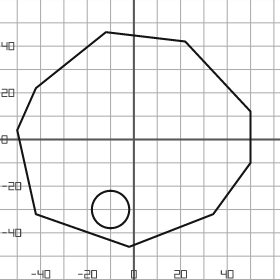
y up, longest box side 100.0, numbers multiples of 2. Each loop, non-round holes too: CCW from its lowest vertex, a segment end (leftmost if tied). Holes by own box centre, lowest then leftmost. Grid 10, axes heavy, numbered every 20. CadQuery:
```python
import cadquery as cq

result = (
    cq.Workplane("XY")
    .moveTo(-2.0, -46.0)
    .lineTo(34.0, -32.0)
    .lineTo(50.0, -10.0)
    .lineTo(50.0, 12.0)
    .lineTo(22.0, 42.0)
    .lineTo(-12.0, 46.0)
    .lineTo(-42.0, 22.0)
    .lineTo(-50.0, 4.0)
    .lineTo(-42.0, -32.0)
    .close()
    .moveTo(-10.0, -30.0)
    .circle(8.0)
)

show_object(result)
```